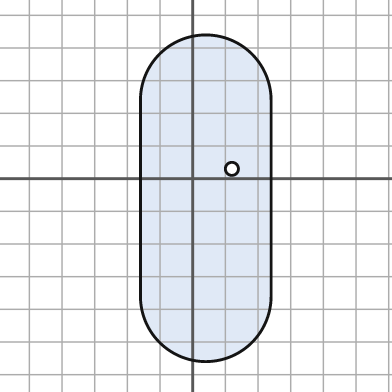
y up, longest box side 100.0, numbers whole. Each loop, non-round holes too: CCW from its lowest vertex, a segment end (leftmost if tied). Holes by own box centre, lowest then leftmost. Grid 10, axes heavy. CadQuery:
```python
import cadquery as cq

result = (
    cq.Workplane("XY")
    .moveTo(-16.0, -36.0)
    .threePointArc((4.0, -56.0), (24.0, -36.0))
    .lineTo(24.0, 24.0)
    .threePointArc((4.0, 44.0), (-16.0, 24.0))
    .close()
    .moveTo(12.0, 3.0)
    .circle(2.0)
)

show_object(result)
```